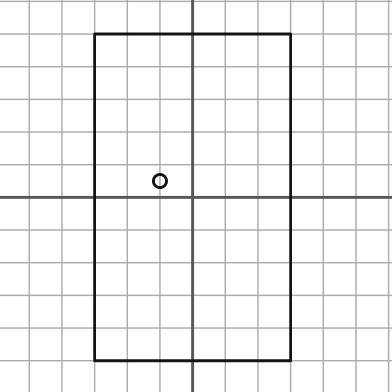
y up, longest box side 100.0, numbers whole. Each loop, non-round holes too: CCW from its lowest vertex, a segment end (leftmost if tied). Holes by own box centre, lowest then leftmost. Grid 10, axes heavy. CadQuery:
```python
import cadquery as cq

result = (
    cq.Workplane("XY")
    .moveTo(-30.0, -50.0)
    .lineTo(30.0, -50.0)
    .lineTo(30.0, 50.0)
    .lineTo(-30.0, 50.0)
    .close()
    .moveTo(-10.0, 5.0)
    .circle(2.0)
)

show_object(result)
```